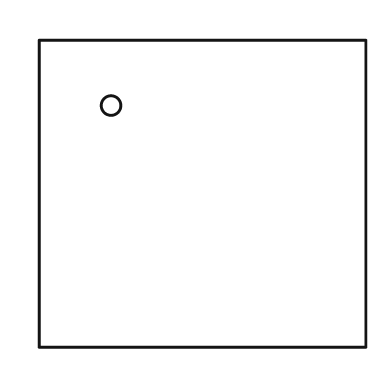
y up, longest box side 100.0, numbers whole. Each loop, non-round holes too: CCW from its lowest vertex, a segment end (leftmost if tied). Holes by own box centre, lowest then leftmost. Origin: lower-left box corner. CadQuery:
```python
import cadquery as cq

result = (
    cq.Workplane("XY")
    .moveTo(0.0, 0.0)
    .lineTo(100.0, 0.0)
    .lineTo(100.0, 94.0)
    .lineTo(0.0, 94.0)
    .close()
    .moveTo(22.0, 74.0)
    .circle(3.0)
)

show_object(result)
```